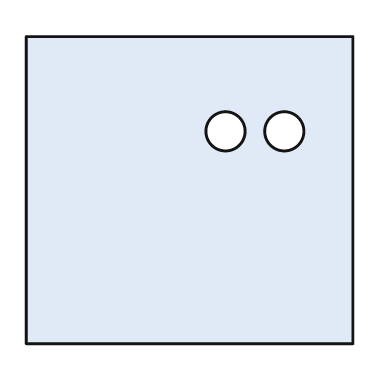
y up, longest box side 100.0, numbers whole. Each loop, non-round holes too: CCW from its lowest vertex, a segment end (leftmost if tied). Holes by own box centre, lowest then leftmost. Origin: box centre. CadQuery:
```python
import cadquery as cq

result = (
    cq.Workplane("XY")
    .moveTo(-50.0, -47.0)
    .lineTo(50.0, -47.0)
    .lineTo(50.0, 47.0)
    .lineTo(-50.0, 47.0)
    .close()
    .moveTo(11.0, 18.0)
    .circle(6.0)
    .moveTo(29.0, 18.0)
    .circle(6.0)
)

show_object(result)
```